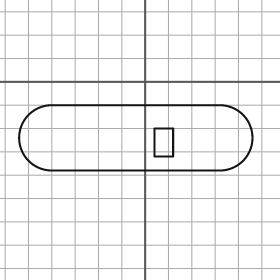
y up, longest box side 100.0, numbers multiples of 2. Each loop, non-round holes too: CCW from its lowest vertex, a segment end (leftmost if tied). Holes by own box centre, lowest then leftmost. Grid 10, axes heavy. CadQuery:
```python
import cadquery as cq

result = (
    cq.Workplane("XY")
    .moveTo(-40.0, -38.0)
    .lineTo(32.0, -38.0)
    .threePointArc((46.0, -24.0), (32.0, -10.0))
    .lineTo(-40.0, -10.0)
    .threePointArc((-54.0, -24.0), (-40.0, -38.0))
    .close()
    .moveTo(4.0, -32.0)
    .lineTo(12.0, -32.0)
    .lineTo(12.0, -20.0)
    .lineTo(4.0, -20.0)
    .close()
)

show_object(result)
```